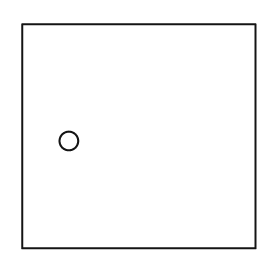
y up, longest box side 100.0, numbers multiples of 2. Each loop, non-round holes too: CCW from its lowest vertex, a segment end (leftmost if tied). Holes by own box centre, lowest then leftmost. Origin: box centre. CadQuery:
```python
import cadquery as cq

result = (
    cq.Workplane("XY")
    .moveTo(-50.0, -48.0)
    .lineTo(50.0, -48.0)
    .lineTo(50.0, 48.0)
    .lineTo(-50.0, 48.0)
    .close()
    .moveTo(-30.0, -2.0)
    .circle(4.0)
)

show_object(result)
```